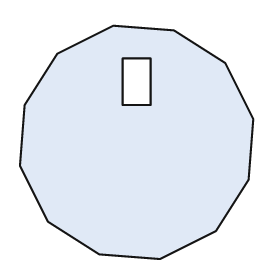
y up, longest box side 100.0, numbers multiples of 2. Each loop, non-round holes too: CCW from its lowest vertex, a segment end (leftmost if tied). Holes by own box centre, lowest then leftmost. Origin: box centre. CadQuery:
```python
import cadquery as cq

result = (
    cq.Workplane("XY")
    .moveTo(10.0, -50.0)
    .lineTo(34.0, -38.0)
    .lineTo(48.0, -16.0)
    .lineTo(50.0, 10.0)
    .lineTo(38.0, 34.0)
    .lineTo(16.0, 48.0)
    .lineTo(-10.0, 50.0)
    .lineTo(-34.0, 38.0)
    .lineTo(-48.0, 16.0)
    .lineTo(-50.0, -10.0)
    .lineTo(-38.0, -34.0)
    .lineTo(-16.0, -48.0)
    .close()
    .moveTo(-6.0, 16.0)
    .lineTo(6.0, 16.0)
    .lineTo(6.0, 36.0)
    .lineTo(-6.0, 36.0)
    .close()
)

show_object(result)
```